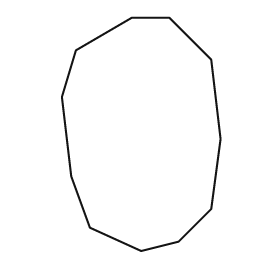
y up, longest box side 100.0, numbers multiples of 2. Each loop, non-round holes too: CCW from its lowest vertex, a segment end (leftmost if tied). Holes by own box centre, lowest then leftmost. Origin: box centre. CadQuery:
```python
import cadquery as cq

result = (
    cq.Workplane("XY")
    .moveTo(0.0, -50.0)
    .lineTo(16.0, -46.0)
    .lineTo(30.0, -32.0)
    .lineTo(34.0, -2.0)
    .lineTo(30.0, 32.0)
    .lineTo(12.0, 50.0)
    .lineTo(-4.0, 50.0)
    .lineTo(-28.0, 36.0)
    .lineTo(-34.0, 16.0)
    .lineTo(-30.0, -18.0)
    .lineTo(-22.0, -40.0)
    .close()
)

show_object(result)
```